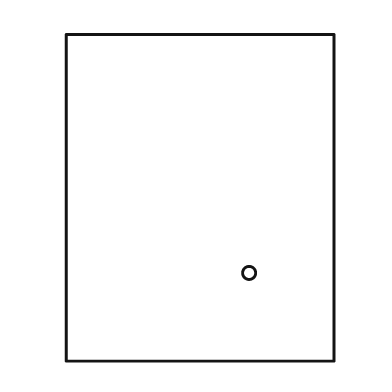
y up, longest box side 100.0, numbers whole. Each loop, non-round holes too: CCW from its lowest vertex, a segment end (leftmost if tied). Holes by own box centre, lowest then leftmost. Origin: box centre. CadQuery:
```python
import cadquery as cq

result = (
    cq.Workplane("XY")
    .moveTo(-41.0, -50.0)
    .lineTo(41.0, -50.0)
    .lineTo(41.0, 50.0)
    .lineTo(-41.0, 50.0)
    .close()
    .moveTo(15.0, -23.0)
    .circle(2.0)
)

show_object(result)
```